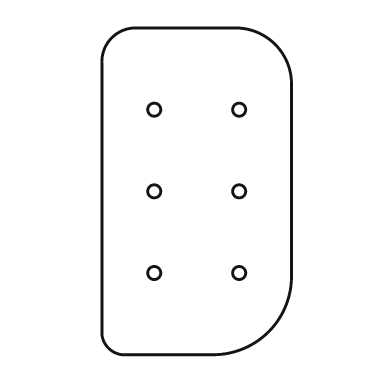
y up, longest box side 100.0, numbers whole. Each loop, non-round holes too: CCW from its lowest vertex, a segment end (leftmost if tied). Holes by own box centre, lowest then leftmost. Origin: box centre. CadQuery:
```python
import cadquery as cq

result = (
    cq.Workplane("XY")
    .moveTo(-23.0, -50.0)
    .lineTo(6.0, -50.0)
    .threePointArc((22.0, -43.0), (29.0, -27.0))
    .lineTo(29.0, 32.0)
    .threePointArc((24.0, 45.0), (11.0, 50.0))
    .lineTo(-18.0, 50.0)
    .threePointArc((-26.0, 47.0), (-29.0, 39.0))
    .lineTo(-29.0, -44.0)
    .threePointArc((-27.0, -48.0), (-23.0, -50.0))
    .close()
    .moveTo(-13.0, -25.0)
    .circle(2.0)
    .moveTo(13.0, -25.0)
    .circle(2.0)
    .moveTo(-13.0, 0.0)
    .circle(2.0)
    .moveTo(13.0, 0.0)
    .circle(2.0)
    .moveTo(-13.0, 25.0)
    .circle(2.0)
    .moveTo(13.0, 25.0)
    .circle(2.0)
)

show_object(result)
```